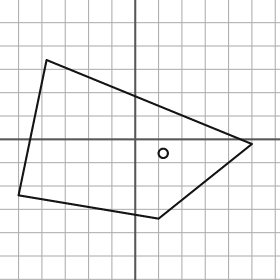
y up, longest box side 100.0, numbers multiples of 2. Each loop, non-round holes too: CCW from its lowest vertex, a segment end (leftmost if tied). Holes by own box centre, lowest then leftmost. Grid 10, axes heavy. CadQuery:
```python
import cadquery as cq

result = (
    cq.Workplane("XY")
    .moveTo(10.0, -34.0)
    .lineTo(50.0, -2.0)
    .lineTo(-38.0, 34.0)
    .lineTo(-50.0, -24.0)
    .close()
    .moveTo(12.0, -6.0)
    .circle(2.0)
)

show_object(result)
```